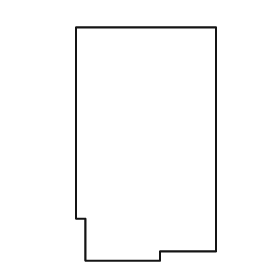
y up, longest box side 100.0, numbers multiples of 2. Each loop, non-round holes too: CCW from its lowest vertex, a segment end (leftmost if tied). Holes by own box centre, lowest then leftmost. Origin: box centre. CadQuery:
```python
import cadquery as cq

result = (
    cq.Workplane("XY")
    .moveTo(-26.0, -50.0)
    .lineTo(6.0, -50.0)
    .lineTo(6.0, -46.0)
    .lineTo(30.0, -46.0)
    .lineTo(30.0, 50.0)
    .lineTo(-30.0, 50.0)
    .lineTo(-30.0, -32.0)
    .lineTo(-26.0, -32.0)
    .close()
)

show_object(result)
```